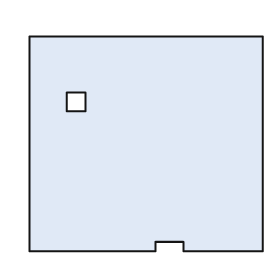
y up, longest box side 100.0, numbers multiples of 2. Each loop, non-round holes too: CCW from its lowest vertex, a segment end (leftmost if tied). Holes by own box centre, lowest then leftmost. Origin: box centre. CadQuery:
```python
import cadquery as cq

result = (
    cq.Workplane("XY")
    .moveTo(-50.0, -46.0)
    .lineTo(4.0, -46.0)
    .lineTo(4.0, -42.0)
    .lineTo(16.0, -42.0)
    .lineTo(16.0, -46.0)
    .lineTo(50.0, -46.0)
    .lineTo(50.0, 46.0)
    .lineTo(-50.0, 46.0)
    .close()
    .moveTo(-34.0, 14.0)
    .lineTo(-26.0, 14.0)
    .lineTo(-26.0, 22.0)
    .lineTo(-34.0, 22.0)
    .close()
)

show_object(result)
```